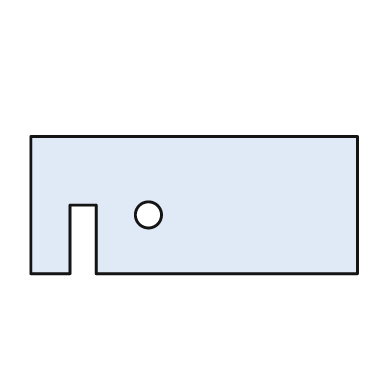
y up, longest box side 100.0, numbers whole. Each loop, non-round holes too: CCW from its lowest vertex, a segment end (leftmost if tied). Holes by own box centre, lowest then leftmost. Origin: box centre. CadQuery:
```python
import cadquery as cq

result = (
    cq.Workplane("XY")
    .moveTo(-50.0, -21.0)
    .lineTo(-38.0, -21.0)
    .lineTo(-38.0, 0.0)
    .lineTo(-30.0, 0.0)
    .lineTo(-30.0, -21.0)
    .lineTo(50.0, -21.0)
    .lineTo(50.0, 21.0)
    .lineTo(-50.0, 21.0)
    .close()
    .moveTo(-14.0, -3.0)
    .circle(4.0)
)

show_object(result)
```